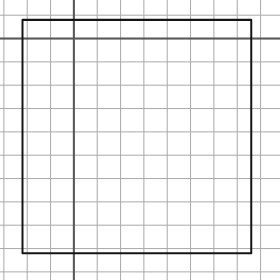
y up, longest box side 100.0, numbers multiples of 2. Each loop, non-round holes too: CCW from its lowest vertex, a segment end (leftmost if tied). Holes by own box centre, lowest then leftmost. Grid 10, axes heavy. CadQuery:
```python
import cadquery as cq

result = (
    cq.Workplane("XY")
    .moveTo(-22.0, -92.0)
    .lineTo(76.0, -92.0)
    .lineTo(76.0, 8.0)
    .lineTo(-22.0, 8.0)
    .close()
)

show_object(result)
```